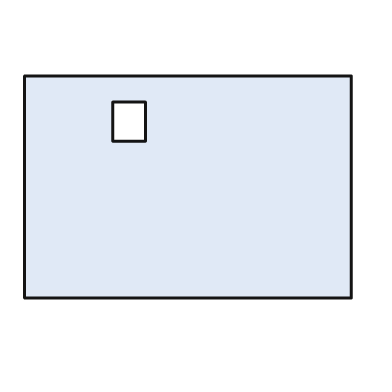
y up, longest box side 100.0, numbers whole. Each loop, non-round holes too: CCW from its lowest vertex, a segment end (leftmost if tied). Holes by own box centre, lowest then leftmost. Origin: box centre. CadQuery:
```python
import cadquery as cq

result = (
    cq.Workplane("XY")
    .moveTo(-50.0, -34.0)
    .lineTo(50.0, -34.0)
    .lineTo(50.0, 34.0)
    .lineTo(-50.0, 34.0)
    .close()
    .moveTo(-23.0, 14.0)
    .lineTo(-13.0, 14.0)
    .lineTo(-13.0, 26.0)
    .lineTo(-23.0, 26.0)
    .close()
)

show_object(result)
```